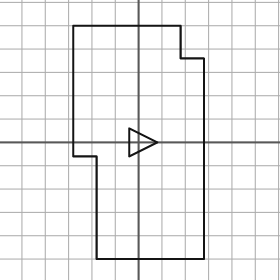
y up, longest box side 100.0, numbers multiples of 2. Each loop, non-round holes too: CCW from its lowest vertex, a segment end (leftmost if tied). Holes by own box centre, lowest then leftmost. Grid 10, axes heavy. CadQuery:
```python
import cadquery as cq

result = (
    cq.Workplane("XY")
    .moveTo(-18.0, -50.0)
    .lineTo(28.0, -50.0)
    .lineTo(28.0, 36.0)
    .lineTo(18.0, 36.0)
    .lineTo(18.0, 50.0)
    .lineTo(-28.0, 50.0)
    .lineTo(-28.0, -6.0)
    .lineTo(-18.0, -6.0)
    .close()
    .moveTo(-4.0, -6.0)
    .lineTo(8.0, 0.0)
    .lineTo(-4.0, 6.0)
    .close()
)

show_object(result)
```